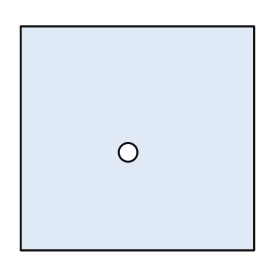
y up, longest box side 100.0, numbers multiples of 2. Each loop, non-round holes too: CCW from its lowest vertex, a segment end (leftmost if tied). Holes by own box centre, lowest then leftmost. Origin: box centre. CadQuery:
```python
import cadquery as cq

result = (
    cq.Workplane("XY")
    .moveTo(-50.0, -48.0)
    .lineTo(50.0, -48.0)
    .lineTo(50.0, 48.0)
    .lineTo(-50.0, 48.0)
    .close()
    .moveTo(-4.0, -6.0)
    .circle(4.0)
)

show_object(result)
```